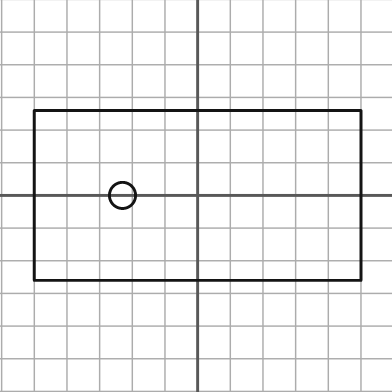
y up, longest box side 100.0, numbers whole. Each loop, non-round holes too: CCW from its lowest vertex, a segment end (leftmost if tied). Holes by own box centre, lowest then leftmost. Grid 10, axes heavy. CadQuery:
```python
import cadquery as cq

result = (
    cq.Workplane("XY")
    .moveTo(-50.0, -26.0)
    .lineTo(50.0, -26.0)
    .lineTo(50.0, 26.0)
    .lineTo(-50.0, 26.0)
    .close()
    .moveTo(-23.0, 0.0)
    .circle(4.0)
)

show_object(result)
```